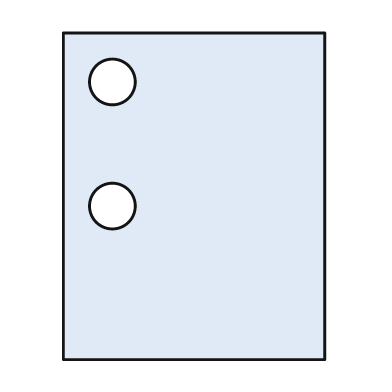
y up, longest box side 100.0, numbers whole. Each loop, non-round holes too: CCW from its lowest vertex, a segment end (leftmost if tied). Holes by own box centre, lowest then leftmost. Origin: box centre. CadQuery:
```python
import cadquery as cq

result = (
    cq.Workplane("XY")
    .moveTo(-40.0, -50.0)
    .lineTo(40.0, -50.0)
    .lineTo(40.0, 50.0)
    .lineTo(-40.0, 50.0)
    .close()
    .moveTo(-25.0, -3.0)
    .circle(7.0)
    .moveTo(-25.0, 35.0)
    .circle(7.0)
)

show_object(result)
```